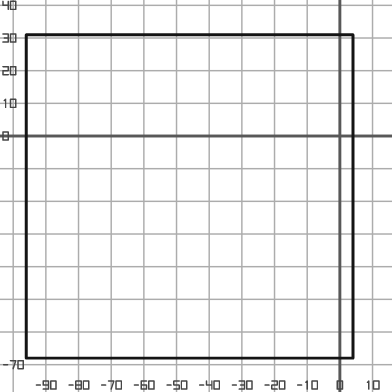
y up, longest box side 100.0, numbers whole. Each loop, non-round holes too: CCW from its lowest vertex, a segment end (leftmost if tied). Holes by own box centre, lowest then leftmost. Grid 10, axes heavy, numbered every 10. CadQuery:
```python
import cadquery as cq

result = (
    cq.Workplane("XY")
    .moveTo(-96.0, -68.0)
    .lineTo(4.0, -68.0)
    .lineTo(4.0, 31.0)
    .lineTo(-96.0, 31.0)
    .close()
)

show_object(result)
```